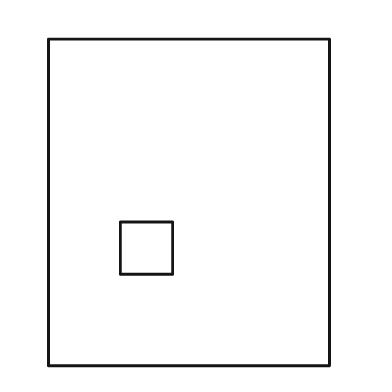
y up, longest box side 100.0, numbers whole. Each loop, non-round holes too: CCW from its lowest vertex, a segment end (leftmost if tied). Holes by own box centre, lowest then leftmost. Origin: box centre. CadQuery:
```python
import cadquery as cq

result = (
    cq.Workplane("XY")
    .moveTo(-43.0, -50.0)
    .lineTo(43.0, -50.0)
    .lineTo(43.0, 50.0)
    .lineTo(-43.0, 50.0)
    .close()
    .moveTo(-21.0, -22.0)
    .lineTo(-5.0, -22.0)
    .lineTo(-5.0, -6.0)
    .lineTo(-21.0, -6.0)
    .close()
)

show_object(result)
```